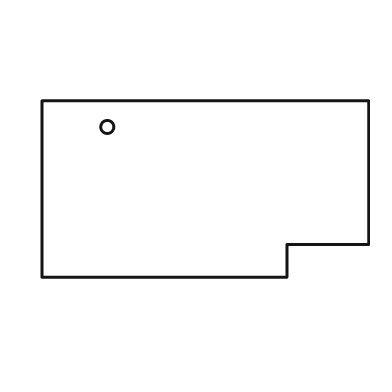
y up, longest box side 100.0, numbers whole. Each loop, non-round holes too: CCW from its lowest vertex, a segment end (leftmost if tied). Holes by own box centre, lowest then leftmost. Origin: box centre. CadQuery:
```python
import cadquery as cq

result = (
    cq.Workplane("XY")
    .moveTo(-50.0, -27.0)
    .lineTo(25.0, -27.0)
    .lineTo(25.0, -17.0)
    .lineTo(50.0, -17.0)
    .lineTo(50.0, 27.0)
    .lineTo(-50.0, 27.0)
    .close()
    .moveTo(-30.0, 19.0)
    .circle(2.0)
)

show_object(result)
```